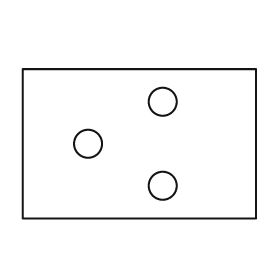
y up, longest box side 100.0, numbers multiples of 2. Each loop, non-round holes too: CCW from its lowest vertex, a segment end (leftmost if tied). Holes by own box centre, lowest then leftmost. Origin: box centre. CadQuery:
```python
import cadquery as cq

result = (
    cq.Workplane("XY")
    .moveTo(-50.0, -32.0)
    .lineTo(50.0, -32.0)
    .lineTo(50.0, 32.0)
    .lineTo(-50.0, 32.0)
    .close()
    .moveTo(10.0, -18.0)
    .circle(6.0)
    .moveTo(-22.0, 0.0)
    .circle(6.0)
    .moveTo(10.0, 18.0)
    .circle(6.0)
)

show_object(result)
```